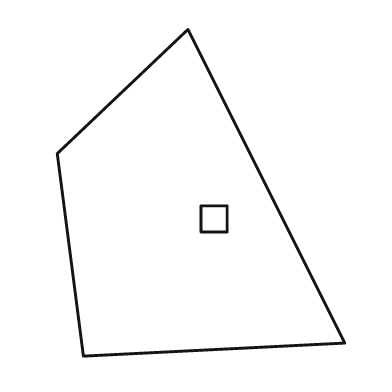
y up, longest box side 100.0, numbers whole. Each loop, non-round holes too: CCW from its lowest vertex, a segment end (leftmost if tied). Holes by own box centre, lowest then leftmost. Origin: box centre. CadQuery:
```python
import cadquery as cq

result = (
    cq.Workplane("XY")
    .moveTo(-36.0, -50.0)
    .lineTo(44.0, -46.0)
    .lineTo(-4.0, 50.0)
    .lineTo(-44.0, 12.0)
    .close()
    .moveTo(0.0, -12.0)
    .lineTo(8.0, -12.0)
    .lineTo(8.0, -4.0)
    .lineTo(0.0, -4.0)
    .close()
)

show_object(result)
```